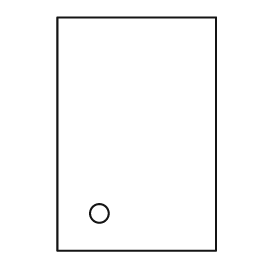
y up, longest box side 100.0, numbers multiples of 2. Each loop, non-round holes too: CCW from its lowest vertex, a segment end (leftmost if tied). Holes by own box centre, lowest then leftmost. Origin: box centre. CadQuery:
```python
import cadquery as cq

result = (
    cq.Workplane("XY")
    .moveTo(-34.0, -50.0)
    .lineTo(34.0, -50.0)
    .lineTo(34.0, 50.0)
    .lineTo(-34.0, 50.0)
    .close()
    .moveTo(-16.0, -34.0)
    .circle(4.0)
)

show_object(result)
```